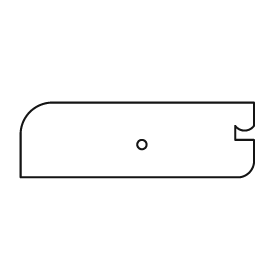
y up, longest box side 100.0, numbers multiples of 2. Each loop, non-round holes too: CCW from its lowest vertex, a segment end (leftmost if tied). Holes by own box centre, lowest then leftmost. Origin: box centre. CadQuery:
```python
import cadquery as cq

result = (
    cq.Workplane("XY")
    .moveTo(-50.0, -16.0)
    .lineTo(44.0, -16.0)
    .threePointArc((48.0, -14.0), (50.0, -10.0))
    .lineTo(50.0, 0.0)
    .lineTo(42.0, 0.0)
    .lineTo(42.0, 6.0)
    .threePointArc((46.0, 4.0), (50.0, 6.0))
    .lineTo(50.0, 16.0)
    .lineTo(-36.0, 16.0)
    .threePointArc((-46.0, 12.0), (-50.0, 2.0))
    .close()
    .moveTo(2.0, -2.0)
    .circle(2.0)
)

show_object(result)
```